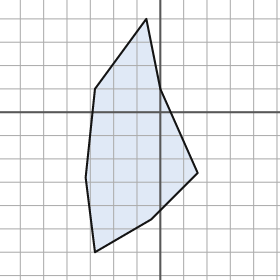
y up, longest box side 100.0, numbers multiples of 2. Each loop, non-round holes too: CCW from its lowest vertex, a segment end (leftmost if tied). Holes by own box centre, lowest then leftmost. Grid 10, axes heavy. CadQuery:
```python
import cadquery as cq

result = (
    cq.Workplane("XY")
    .moveTo(-28.0, -60.0)
    .lineTo(-4.0, -46.0)
    .lineTo(16.0, -26.0)
    .lineTo(0.0, 10.0)
    .lineTo(-6.0, 40.0)
    .lineTo(-28.0, 10.0)
    .lineTo(-32.0, -28.0)
    .close()
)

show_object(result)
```